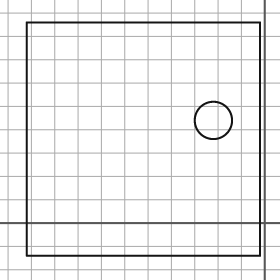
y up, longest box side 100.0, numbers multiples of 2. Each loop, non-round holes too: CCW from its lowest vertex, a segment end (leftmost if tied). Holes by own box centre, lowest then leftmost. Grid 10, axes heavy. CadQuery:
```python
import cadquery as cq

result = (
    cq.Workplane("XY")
    .moveTo(-102.0, -14.0)
    .lineTo(-2.0, -14.0)
    .lineTo(-2.0, 86.0)
    .lineTo(-102.0, 86.0)
    .close()
    .moveTo(-22.0, 44.0)
    .circle(8.0)
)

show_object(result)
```